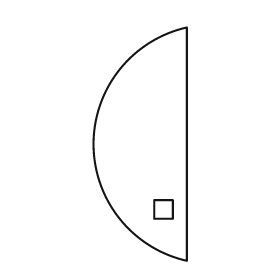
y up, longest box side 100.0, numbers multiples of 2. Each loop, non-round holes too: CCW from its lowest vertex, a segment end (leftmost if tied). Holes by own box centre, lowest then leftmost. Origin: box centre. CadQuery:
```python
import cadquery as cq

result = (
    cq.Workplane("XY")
    .moveTo(20.0, -50.0)
    .lineTo(20.0, 50.0)
    .threePointArc((-20.0, 0.0), (20.0, -50.0))
    .close()
    .moveTo(6.0, -32.0)
    .lineTo(14.0, -32.0)
    .lineTo(14.0, -24.0)
    .lineTo(6.0, -24.0)
    .close()
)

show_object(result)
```